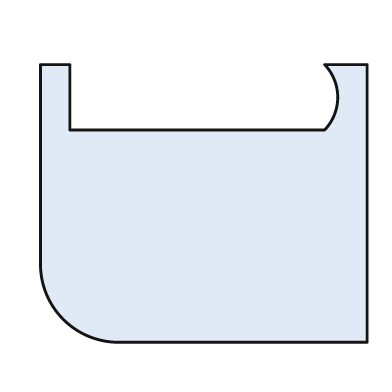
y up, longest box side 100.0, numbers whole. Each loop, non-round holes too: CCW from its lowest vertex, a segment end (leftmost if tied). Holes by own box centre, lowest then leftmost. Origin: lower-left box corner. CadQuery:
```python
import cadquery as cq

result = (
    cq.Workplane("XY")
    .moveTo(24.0, 0.0)
    .lineTo(100.0, 0.0)
    .lineTo(100.0, 85.0)
    .lineTo(87.0, 85.0)
    .threePointArc((91.0, 75.0), (87.0, 65.0))
    .lineTo(9.0, 65.0)
    .lineTo(9.0, 85.0)
    .lineTo(0.0, 85.0)
    .lineTo(0.0, 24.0)
    .threePointArc((7.0, 7.0), (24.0, 0.0))
    .close()
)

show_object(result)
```